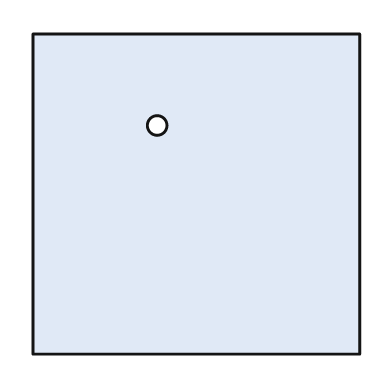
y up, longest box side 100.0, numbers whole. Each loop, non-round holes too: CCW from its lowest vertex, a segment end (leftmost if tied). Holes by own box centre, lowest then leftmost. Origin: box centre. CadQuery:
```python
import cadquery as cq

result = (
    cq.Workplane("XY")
    .moveTo(-50.0, -49.0)
    .lineTo(50.0, -49.0)
    .lineTo(50.0, 49.0)
    .lineTo(-50.0, 49.0)
    .close()
    .moveTo(-12.0, 21.0)
    .circle(3.0)
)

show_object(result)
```